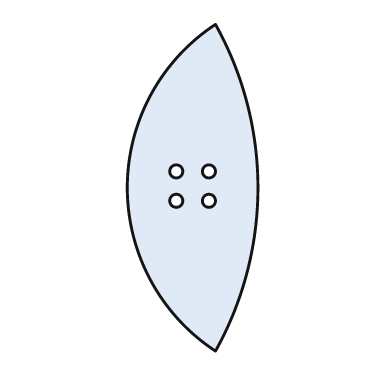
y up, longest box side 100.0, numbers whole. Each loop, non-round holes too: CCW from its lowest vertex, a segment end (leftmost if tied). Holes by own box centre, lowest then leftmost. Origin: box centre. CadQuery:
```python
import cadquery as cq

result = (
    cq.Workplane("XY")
    .moveTo(7.0, -50.0)
    .threePointArc((20.0, 0.0), (7.0, 50.0))
    .threePointArc((-20.0, 0.0), (7.0, -50.0))
    .close()
    .moveTo(-5.0, -4.0)
    .circle(2.0)
    .moveTo(5.0, -4.0)
    .circle(2.0)
    .moveTo(-5.0, 5.0)
    .circle(2.0)
    .moveTo(5.0, 5.0)
    .circle(2.0)
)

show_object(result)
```